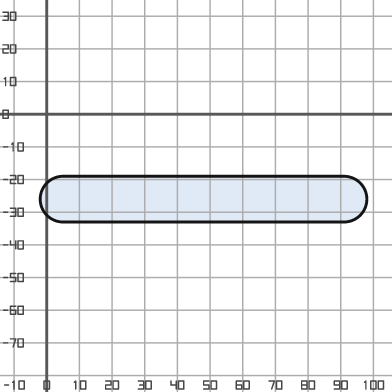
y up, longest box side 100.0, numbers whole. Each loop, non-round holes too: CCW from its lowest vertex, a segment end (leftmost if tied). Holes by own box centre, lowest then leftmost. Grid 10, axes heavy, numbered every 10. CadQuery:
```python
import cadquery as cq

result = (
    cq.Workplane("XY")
    .moveTo(5.0, -33.0)
    .lineTo(91.0, -33.0)
    .threePointArc((98.0, -26.0), (91.0, -19.0))
    .lineTo(5.0, -19.0)
    .threePointArc((-2.0, -26.0), (5.0, -33.0))
    .close()
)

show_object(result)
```